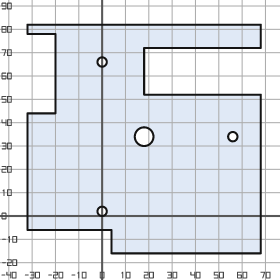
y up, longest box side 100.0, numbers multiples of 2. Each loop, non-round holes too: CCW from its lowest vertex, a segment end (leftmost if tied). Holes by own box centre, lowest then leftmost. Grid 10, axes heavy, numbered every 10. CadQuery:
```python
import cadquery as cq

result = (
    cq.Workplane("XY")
    .moveTo(4.0, -16.0)
    .lineTo(68.0, -16.0)
    .lineTo(68.0, 52.0)
    .lineTo(18.0, 52.0)
    .lineTo(18.0, 72.0)
    .lineTo(68.0, 72.0)
    .lineTo(68.0, 82.0)
    .lineTo(-32.0, 82.0)
    .lineTo(-32.0, 78.0)
    .lineTo(-20.0, 78.0)
    .lineTo(-20.0, 44.0)
    .lineTo(-32.0, 44.0)
    .lineTo(-32.0, -6.0)
    .lineTo(4.0, -6.0)
    .close()
    .moveTo(0.0, 2.0)
    .circle(2.0)
    .moveTo(18.0, 34.0)
    .circle(4.0)
    .moveTo(56.0, 34.0)
    .circle(2.0)
    .moveTo(0.0, 66.0)
    .circle(2.0)
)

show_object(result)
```